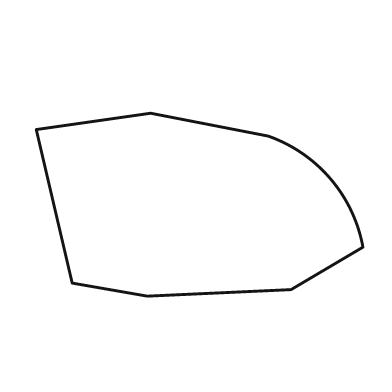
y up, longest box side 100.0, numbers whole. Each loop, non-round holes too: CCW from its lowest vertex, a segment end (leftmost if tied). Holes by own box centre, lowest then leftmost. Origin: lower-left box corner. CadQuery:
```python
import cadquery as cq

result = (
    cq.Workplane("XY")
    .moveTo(34.0, 0.0)
    .lineTo(78.0, 2.0)
    .lineTo(100.0, 15.0)
    .threePointArc((90.0, 36.0), (71.0, 49.0))
    .lineTo(35.0, 56.0)
    .lineTo(0.0, 51.0)
    .lineTo(11.0, 4.0)
    .close()
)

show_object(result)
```